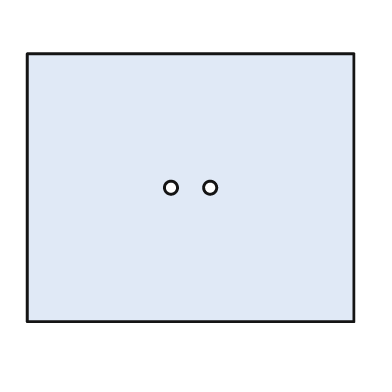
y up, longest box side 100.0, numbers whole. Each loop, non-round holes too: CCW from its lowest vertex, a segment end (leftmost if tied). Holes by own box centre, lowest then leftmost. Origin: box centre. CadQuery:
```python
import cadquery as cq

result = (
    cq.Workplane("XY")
    .moveTo(-50.0, -41.0)
    .lineTo(50.0, -41.0)
    .lineTo(50.0, 41.0)
    .lineTo(-50.0, 41.0)
    .close()
    .moveTo(-6.0, 0.0)
    .circle(2.0)
    .moveTo(6.0, 0.0)
    .circle(2.0)
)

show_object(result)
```